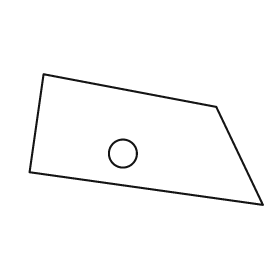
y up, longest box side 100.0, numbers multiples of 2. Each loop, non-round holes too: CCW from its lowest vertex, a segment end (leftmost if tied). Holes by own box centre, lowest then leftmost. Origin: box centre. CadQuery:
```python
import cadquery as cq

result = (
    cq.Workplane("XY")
    .moveTo(50.0, -28.0)
    .lineTo(30.0, 14.0)
    .lineTo(-44.0, 28.0)
    .lineTo(-50.0, -14.0)
    .close()
    .moveTo(-10.0, -6.0)
    .circle(6.0)
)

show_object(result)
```